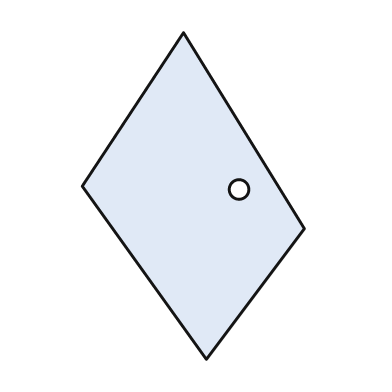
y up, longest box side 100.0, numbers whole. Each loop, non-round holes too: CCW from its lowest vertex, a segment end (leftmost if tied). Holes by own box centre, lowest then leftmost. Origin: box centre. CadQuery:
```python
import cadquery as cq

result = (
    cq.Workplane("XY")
    .moveTo(4.0, -50.0)
    .lineTo(34.0, -10.0)
    .lineTo(-3.0, 50.0)
    .lineTo(-34.0, 3.0)
    .close()
    .moveTo(14.0, 2.0)
    .circle(3.0)
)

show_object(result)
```